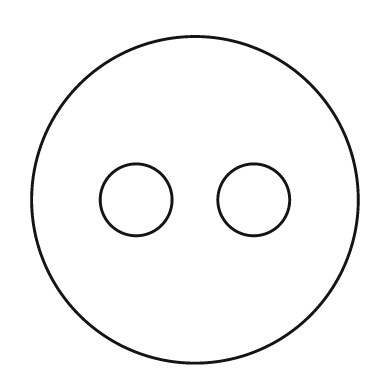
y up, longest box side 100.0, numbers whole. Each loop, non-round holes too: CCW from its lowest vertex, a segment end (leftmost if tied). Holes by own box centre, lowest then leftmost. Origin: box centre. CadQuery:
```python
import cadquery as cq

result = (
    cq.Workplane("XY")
    .moveTo(0.0, 0.0)
    .circle(50.0)
    .moveTo(-18.0, 0.0)
    .circle(11.0)
    .moveTo(18.0, 0.0)
    .circle(11.0)
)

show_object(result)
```